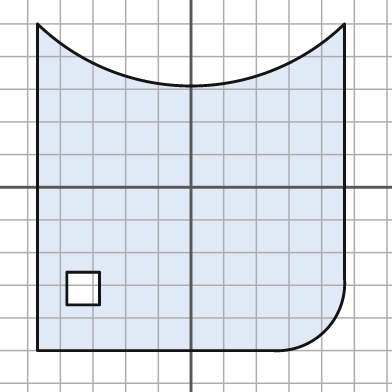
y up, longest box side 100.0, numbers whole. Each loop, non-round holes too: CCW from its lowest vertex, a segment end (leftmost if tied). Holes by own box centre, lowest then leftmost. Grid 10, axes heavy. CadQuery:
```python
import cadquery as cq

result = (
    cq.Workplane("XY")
    .moveTo(-47.0, -50.0)
    .lineTo(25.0, -50.0)
    .threePointArc((41.0, -44.0), (47.0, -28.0))
    .lineTo(47.0, 50.0)
    .threePointArc((0.0, 31.0), (-47.0, 50.0))
    .close()
    .moveTo(-38.0, -36.0)
    .lineTo(-28.0, -36.0)
    .lineTo(-28.0, -26.0)
    .lineTo(-38.0, -26.0)
    .close()
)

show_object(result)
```